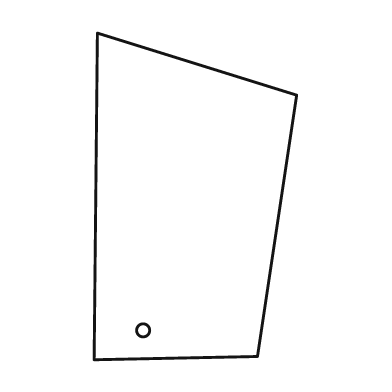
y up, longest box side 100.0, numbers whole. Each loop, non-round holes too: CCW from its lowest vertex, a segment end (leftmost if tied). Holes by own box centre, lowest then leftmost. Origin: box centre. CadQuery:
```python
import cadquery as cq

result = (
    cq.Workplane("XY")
    .moveTo(-31.0, -50.0)
    .lineTo(19.0, -49.0)
    .lineTo(31.0, 31.0)
    .lineTo(-30.0, 50.0)
    .close()
    .moveTo(-16.0, -41.0)
    .circle(2.0)
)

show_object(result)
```